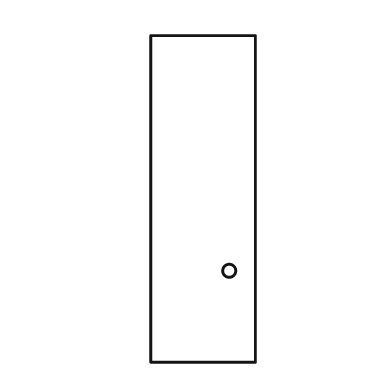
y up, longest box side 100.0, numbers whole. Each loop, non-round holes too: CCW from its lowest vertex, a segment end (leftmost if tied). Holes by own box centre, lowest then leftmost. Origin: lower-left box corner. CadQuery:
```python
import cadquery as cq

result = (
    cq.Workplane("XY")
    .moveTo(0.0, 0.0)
    .lineTo(32.0, 0.0)
    .lineTo(32.0, 100.0)
    .lineTo(0.0, 100.0)
    .close()
    .moveTo(24.0, 28.0)
    .circle(2.0)
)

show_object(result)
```